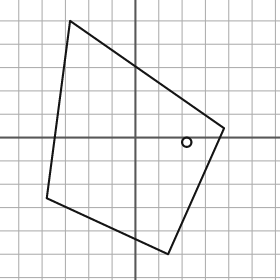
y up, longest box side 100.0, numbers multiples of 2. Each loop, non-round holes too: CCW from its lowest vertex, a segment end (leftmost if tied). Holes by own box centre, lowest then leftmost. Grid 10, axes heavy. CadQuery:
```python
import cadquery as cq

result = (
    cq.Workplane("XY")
    .moveTo(14.0, -50.0)
    .lineTo(38.0, 4.0)
    .lineTo(-28.0, 50.0)
    .lineTo(-38.0, -26.0)
    .close()
    .moveTo(22.0, -2.0)
    .circle(2.0)
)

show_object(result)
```